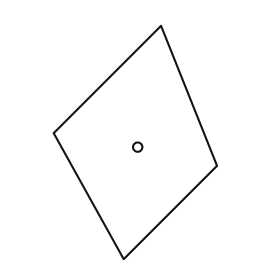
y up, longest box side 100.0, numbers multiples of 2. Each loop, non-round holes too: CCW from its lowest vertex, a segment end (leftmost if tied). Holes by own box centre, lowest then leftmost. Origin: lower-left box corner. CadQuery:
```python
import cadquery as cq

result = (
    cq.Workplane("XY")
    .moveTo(30.0, 0.0)
    .lineTo(70.0, 40.0)
    .lineTo(46.0, 100.0)
    .lineTo(0.0, 54.0)
    .close()
    .moveTo(36.0, 48.0)
    .circle(2.0)
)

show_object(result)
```